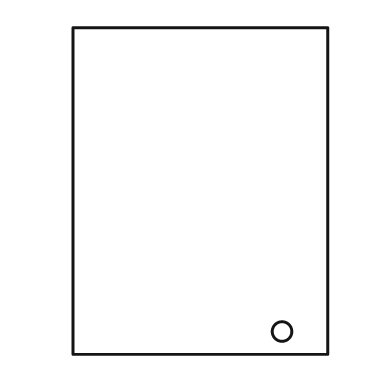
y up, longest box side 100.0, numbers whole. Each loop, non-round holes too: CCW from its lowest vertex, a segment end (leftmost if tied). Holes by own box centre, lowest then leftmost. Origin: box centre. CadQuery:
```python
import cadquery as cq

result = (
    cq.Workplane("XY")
    .moveTo(-39.0, -50.0)
    .lineTo(39.0, -50.0)
    .lineTo(39.0, 50.0)
    .lineTo(-39.0, 50.0)
    .close()
    .moveTo(25.0, -43.0)
    .circle(3.0)
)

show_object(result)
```